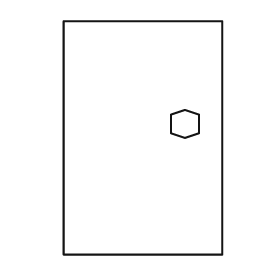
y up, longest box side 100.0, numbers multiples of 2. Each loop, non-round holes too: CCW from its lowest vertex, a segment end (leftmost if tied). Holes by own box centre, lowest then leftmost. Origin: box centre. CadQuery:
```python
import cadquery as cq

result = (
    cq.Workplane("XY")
    .moveTo(-34.0, -50.0)
    .lineTo(34.0, -50.0)
    .lineTo(34.0, 50.0)
    .lineTo(-34.0, 50.0)
    .close()
    .moveTo(18.0, 0.0)
    .lineTo(24.0, 2.0)
    .lineTo(24.0, 10.0)
    .lineTo(18.0, 12.0)
    .lineTo(12.0, 10.0)
    .lineTo(12.0, 2.0)
    .close()
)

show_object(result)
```